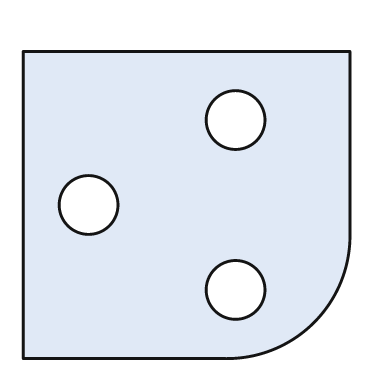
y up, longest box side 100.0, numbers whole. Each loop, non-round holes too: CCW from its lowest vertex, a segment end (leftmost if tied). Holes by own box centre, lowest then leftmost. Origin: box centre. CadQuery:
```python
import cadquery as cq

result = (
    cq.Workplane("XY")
    .moveTo(-50.0, -47.0)
    .lineTo(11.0, -47.0)
    .threePointArc((39.0, -36.0), (50.0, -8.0))
    .lineTo(50.0, 47.0)
    .lineTo(-50.0, 47.0)
    .close()
    .moveTo(15.0, -26.0)
    .circle(9.0)
    .moveTo(-30.0, 0.0)
    .circle(9.0)
    .moveTo(15.0, 26.0)
    .circle(9.0)
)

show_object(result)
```